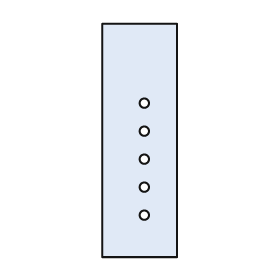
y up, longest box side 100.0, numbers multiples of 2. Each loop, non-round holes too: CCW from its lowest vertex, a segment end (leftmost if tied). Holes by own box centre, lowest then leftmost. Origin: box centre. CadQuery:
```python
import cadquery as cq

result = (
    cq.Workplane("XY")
    .moveTo(-16.0, -50.0)
    .lineTo(16.0, -50.0)
    .lineTo(16.0, 50.0)
    .lineTo(-16.0, 50.0)
    .close()
    .moveTo(2.0, -32.0)
    .circle(2.0)
    .moveTo(2.0, -20.0)
    .circle(2.0)
    .moveTo(2.0, -8.0)
    .circle(2.0)
    .moveTo(2.0, 4.0)
    .circle(2.0)
    .moveTo(2.0, 16.0)
    .circle(2.0)
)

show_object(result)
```